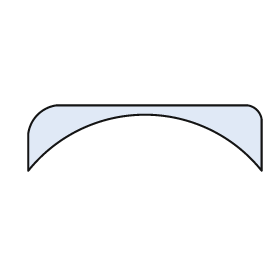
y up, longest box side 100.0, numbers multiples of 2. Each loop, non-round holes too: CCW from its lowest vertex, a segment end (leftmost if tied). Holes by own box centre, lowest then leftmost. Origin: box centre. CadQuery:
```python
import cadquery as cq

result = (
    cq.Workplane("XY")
    .moveTo(-50.0, -14.0)
    .threePointArc((0.0, 10.0), (50.0, -14.0))
    .lineTo(50.0, 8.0)
    .threePointArc((48.0, 12.0), (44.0, 14.0))
    .lineTo(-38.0, 14.0)
    .threePointArc((-46.0, 10.0), (-50.0, 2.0))
    .close()
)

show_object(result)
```